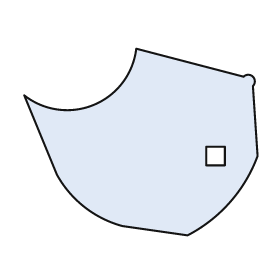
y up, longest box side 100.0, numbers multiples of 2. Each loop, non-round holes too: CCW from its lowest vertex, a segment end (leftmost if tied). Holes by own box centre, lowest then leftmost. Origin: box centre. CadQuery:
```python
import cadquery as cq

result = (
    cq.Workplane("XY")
    .moveTo(20.0, -40.0)
    .threePointArc((38.0, -26.0), (50.0, -6.0))
    .lineTo(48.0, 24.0)
    .threePointArc((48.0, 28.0), (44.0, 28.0))
    .lineTo(-2.0, 40.0)
    .threePointArc((-20.0, 16.0), (-50.0, 20.0))
    .lineTo(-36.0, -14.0)
    .threePointArc((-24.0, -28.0), (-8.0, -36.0))
    .close()
    .moveTo(28.0, -10.0)
    .lineTo(36.0, -10.0)
    .lineTo(36.0, -2.0)
    .lineTo(28.0, -2.0)
    .close()
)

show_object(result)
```